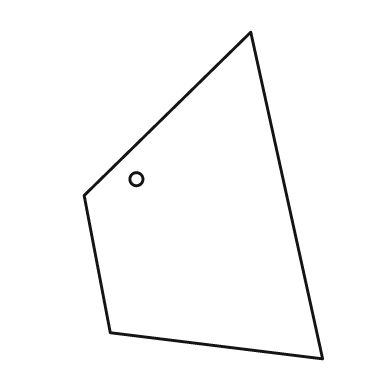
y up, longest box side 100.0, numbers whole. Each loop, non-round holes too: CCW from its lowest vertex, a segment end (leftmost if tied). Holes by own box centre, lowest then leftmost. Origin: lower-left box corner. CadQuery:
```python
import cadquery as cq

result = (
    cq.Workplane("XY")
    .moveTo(73.0, 0.0)
    .lineTo(51.0, 100.0)
    .lineTo(0.0, 50.0)
    .lineTo(8.0, 8.0)
    .close()
    .moveTo(16.0, 55.0)
    .circle(2.0)
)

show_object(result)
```